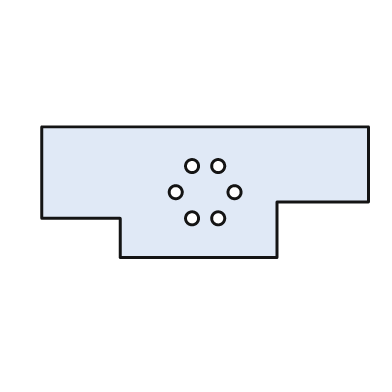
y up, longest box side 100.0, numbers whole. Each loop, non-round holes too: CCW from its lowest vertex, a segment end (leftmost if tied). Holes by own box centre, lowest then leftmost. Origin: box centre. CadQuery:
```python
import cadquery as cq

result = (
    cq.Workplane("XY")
    .moveTo(-26.0, -20.0)
    .lineTo(22.0, -20.0)
    .lineTo(22.0, -3.0)
    .lineTo(50.0, -3.0)
    .lineTo(50.0, 20.0)
    .lineTo(-50.0, 20.0)
    .lineTo(-50.0, -8.0)
    .lineTo(-26.0, -8.0)
    .close()
    .moveTo(-4.0, -8.0)
    .circle(2.0)
    .moveTo(4.0, -8.0)
    .circle(2.0)
    .moveTo(-9.0, 0.0)
    .circle(2.0)
    .moveTo(9.0, 0.0)
    .circle(2.0)
    .moveTo(-4.0, 8.0)
    .circle(2.0)
    .moveTo(4.0, 8.0)
    .circle(2.0)
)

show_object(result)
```